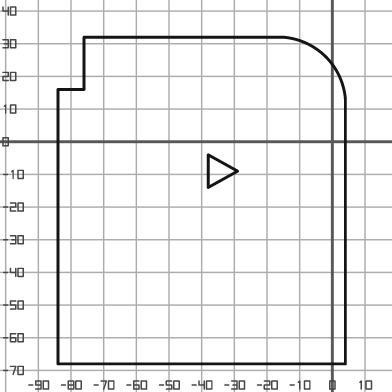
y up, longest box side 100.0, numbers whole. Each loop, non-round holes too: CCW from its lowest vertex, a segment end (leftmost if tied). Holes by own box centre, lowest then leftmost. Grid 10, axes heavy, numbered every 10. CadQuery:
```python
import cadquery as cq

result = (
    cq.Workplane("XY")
    .moveTo(-84.0, -68.0)
    .lineTo(4.0, -68.0)
    .lineTo(4.0, 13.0)
    .threePointArc((-2.0, 26.0), (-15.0, 32.0))
    .lineTo(-76.0, 32.0)
    .lineTo(-76.0, 16.0)
    .lineTo(-84.0, 16.0)
    .close()
    .moveTo(-38.0, -14.0)
    .lineTo(-29.0, -9.0)
    .lineTo(-38.0, -4.0)
    .close()
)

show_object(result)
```